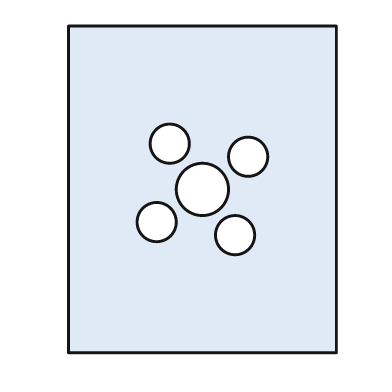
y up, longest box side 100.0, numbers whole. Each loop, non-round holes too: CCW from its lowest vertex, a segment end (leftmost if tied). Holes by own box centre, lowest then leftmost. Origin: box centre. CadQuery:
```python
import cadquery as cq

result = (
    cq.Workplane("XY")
    .moveTo(-41.0, -50.0)
    .lineTo(41.0, -50.0)
    .lineTo(41.0, 50.0)
    .lineTo(-41.0, 50.0)
    .close()
    .moveTo(10.0, -14.0)
    .circle(6.0)
    .moveTo(-14.0, -10.0)
    .circle(6.0)
    .moveTo(0.0, 0.0)
    .circle(8.0)
    .moveTo(14.0, 10.0)
    .circle(6.0)
    .moveTo(-10.0, 14.0)
    .circle(6.0)
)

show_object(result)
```